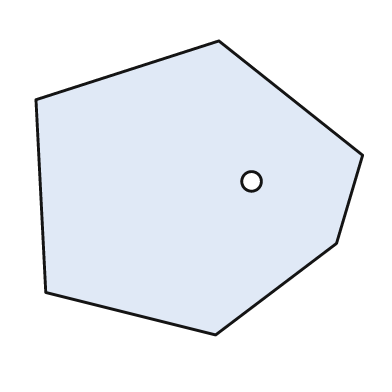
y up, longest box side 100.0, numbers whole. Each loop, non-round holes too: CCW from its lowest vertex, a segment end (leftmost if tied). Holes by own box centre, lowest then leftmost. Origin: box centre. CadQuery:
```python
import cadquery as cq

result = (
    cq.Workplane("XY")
    .moveTo(5.0, -45.0)
    .lineTo(42.0, -17.0)
    .lineTo(50.0, 10.0)
    .lineTo(6.0, 45.0)
    .lineTo(-50.0, 27.0)
    .lineTo(-47.0, -32.0)
    .close()
    .moveTo(16.0, 2.0)
    .circle(3.0)
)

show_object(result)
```